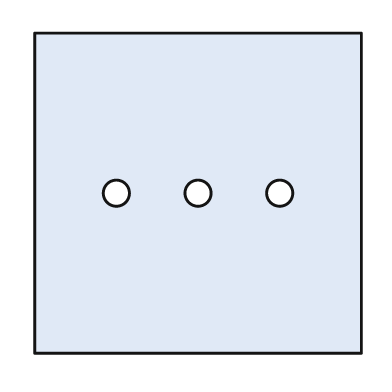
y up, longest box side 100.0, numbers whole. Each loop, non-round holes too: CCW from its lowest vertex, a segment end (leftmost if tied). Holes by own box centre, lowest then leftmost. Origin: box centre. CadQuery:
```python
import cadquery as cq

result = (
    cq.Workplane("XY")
    .moveTo(-50.0, -49.0)
    .lineTo(50.0, -49.0)
    .lineTo(50.0, 49.0)
    .lineTo(-50.0, 49.0)
    .close()
    .moveTo(-25.0, 0.0)
    .circle(4.0)
    .moveTo(0.0, 0.0)
    .circle(4.0)
    .moveTo(25.0, 0.0)
    .circle(4.0)
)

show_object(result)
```